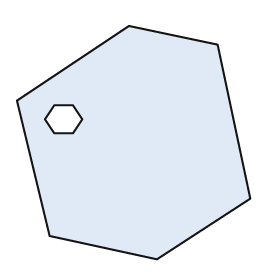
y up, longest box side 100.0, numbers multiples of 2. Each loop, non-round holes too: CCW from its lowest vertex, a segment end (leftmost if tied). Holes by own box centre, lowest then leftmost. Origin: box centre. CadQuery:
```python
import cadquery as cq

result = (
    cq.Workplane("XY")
    .moveTo(10.0, -50.0)
    .lineTo(50.0, -24.0)
    .lineTo(36.0, 42.0)
    .lineTo(-2.0, 50.0)
    .lineTo(-50.0, 18.0)
    .lineTo(-36.0, -40.0)
    .close()
    .moveTo(-34.0, 4.0)
    .lineTo(-26.0, 4.0)
    .lineTo(-22.0, 10.0)
    .lineTo(-26.0, 16.0)
    .lineTo(-34.0, 16.0)
    .lineTo(-38.0, 10.0)
    .close()
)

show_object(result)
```